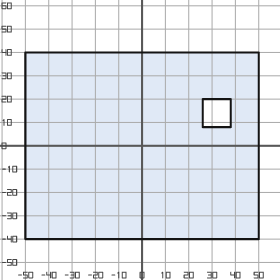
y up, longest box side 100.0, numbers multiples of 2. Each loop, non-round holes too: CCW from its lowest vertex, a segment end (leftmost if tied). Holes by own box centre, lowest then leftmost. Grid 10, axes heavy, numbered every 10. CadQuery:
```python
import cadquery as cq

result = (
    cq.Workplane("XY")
    .moveTo(-50.0, -40.0)
    .lineTo(50.0, -40.0)
    .lineTo(50.0, 40.0)
    .lineTo(-50.0, 40.0)
    .close()
    .moveTo(26.0, 8.0)
    .lineTo(38.0, 8.0)
    .lineTo(38.0, 20.0)
    .lineTo(26.0, 20.0)
    .close()
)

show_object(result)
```